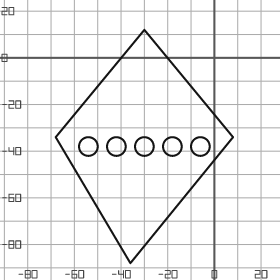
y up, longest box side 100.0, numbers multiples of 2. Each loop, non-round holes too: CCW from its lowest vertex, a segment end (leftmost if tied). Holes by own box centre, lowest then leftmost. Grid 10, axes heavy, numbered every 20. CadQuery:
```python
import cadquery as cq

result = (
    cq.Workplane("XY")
    .moveTo(-36.0, -88.0)
    .lineTo(8.0, -34.0)
    .lineTo(-30.0, 12.0)
    .lineTo(-68.0, -34.0)
    .close()
    .moveTo(-54.0, -38.0)
    .circle(4.0)
    .moveTo(-42.0, -38.0)
    .circle(4.0)
    .moveTo(-30.0, -38.0)
    .circle(4.0)
    .moveTo(-18.0, -38.0)
    .circle(4.0)
    .moveTo(-6.0, -38.0)
    .circle(4.0)
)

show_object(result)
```